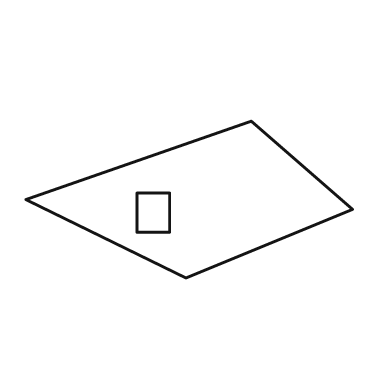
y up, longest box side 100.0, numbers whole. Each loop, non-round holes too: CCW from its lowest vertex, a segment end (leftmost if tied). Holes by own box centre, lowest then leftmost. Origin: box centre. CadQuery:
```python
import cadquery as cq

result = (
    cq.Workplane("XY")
    .moveTo(-1.0, -24.0)
    .lineTo(50.0, -3.0)
    .lineTo(19.0, 24.0)
    .lineTo(-50.0, 0.0)
    .close()
    .moveTo(-16.0, -10.0)
    .lineTo(-6.0, -10.0)
    .lineTo(-6.0, 2.0)
    .lineTo(-16.0, 2.0)
    .close()
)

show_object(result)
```